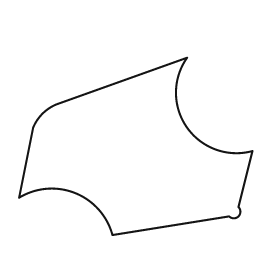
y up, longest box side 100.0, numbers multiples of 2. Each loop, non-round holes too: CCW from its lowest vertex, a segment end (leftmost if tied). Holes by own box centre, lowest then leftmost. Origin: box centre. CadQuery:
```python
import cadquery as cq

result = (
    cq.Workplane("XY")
    .moveTo(-10.0, -38.0)
    .lineTo(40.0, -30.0)
    .threePointArc((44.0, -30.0), (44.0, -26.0))
    .lineTo(50.0, -2.0)
    .threePointArc((22.0, 8.0), (22.0, 38.0))
    .lineTo(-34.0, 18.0)
    .threePointArc((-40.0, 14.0), (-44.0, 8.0))
    .lineTo(-50.0, -22.0)
    .threePointArc((-26.0, -20.0), (-10.0, -38.0))
    .close()
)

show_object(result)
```